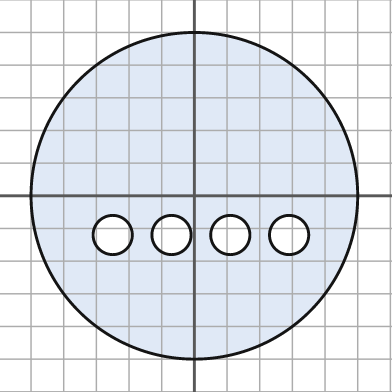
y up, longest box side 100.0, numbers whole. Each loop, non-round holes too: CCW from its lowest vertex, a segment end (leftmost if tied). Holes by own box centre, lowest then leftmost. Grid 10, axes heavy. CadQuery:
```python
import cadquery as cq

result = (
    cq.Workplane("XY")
    .moveTo(0.0, 0.0)
    .circle(50.0)
    .moveTo(-25.0, -12.0)
    .circle(6.0)
    .moveTo(-7.0, -12.0)
    .circle(6.0)
    .moveTo(11.0, -12.0)
    .circle(6.0)
    .moveTo(29.0, -12.0)
    .circle(6.0)
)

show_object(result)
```